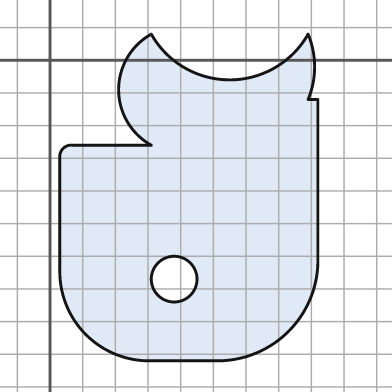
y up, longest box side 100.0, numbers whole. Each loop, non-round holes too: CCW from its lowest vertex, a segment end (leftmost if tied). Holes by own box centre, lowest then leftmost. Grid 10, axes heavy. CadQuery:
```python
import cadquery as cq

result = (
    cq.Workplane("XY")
    .moveTo(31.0, -92.0)
    .lineTo(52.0, -92.0)
    .threePointArc((73.0, -83.0), (82.0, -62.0))
    .lineTo(82.0, -12.0)
    .lineTo(79.0, -12.0)
    .threePointArc((81.0, -2.0), (79.0, 8.0))
    .threePointArc((55.0, -6.0), (31.0, 8.0))
    .threePointArc((21.0, -9.0), (31.0, -26.0))
    .lineTo(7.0, -26.0)
    .threePointArc((4.0, -27.0), (3.0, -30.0))
    .lineTo(3.0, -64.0)
    .threePointArc((11.0, -84.0), (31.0, -92.0))
    .close()
    .moveTo(38.0, -67.0)
    .circle(7.0)
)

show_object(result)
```